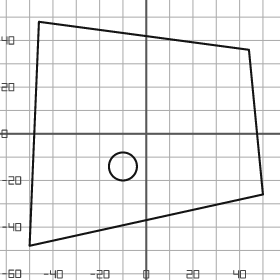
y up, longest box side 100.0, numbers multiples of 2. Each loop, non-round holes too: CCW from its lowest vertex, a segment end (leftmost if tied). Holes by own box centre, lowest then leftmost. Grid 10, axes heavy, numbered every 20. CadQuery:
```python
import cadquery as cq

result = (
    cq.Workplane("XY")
    .moveTo(-50.0, -48.0)
    .lineTo(50.0, -26.0)
    .lineTo(44.0, 36.0)
    .lineTo(-46.0, 48.0)
    .close()
    .moveTo(-10.0, -14.0)
    .circle(6.0)
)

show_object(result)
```